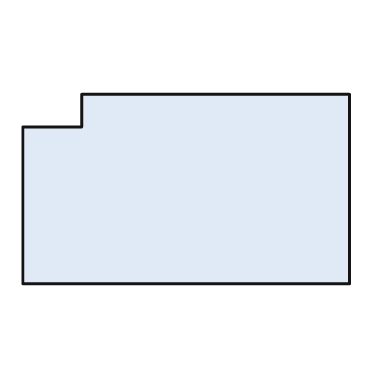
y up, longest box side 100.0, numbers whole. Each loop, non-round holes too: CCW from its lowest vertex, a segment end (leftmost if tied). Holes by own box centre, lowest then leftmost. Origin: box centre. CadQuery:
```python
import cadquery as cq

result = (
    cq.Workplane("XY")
    .moveTo(-50.0, -29.0)
    .lineTo(50.0, -29.0)
    .lineTo(50.0, 29.0)
    .lineTo(-32.0, 29.0)
    .lineTo(-32.0, 19.0)
    .lineTo(-50.0, 19.0)
    .close()
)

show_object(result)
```